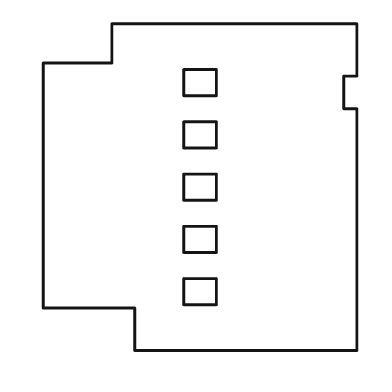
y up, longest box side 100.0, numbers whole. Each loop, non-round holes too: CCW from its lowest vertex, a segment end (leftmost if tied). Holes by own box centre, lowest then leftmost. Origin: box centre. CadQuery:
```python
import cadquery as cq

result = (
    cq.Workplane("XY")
    .moveTo(-20.0, -50.0)
    .lineTo(48.0, -50.0)
    .lineTo(48.0, 24.0)
    .lineTo(44.0, 24.0)
    .lineTo(44.0, 34.0)
    .lineTo(48.0, 34.0)
    .lineTo(48.0, 50.0)
    .lineTo(-27.0, 50.0)
    .lineTo(-27.0, 38.0)
    .lineTo(-48.0, 38.0)
    .lineTo(-48.0, -37.0)
    .lineTo(-20.0, -37.0)
    .close()
    .moveTo(-5.0, -36.0)
    .lineTo(5.0, -36.0)
    .lineTo(5.0, -28.0)
    .lineTo(-5.0, -28.0)
    .close()
    .moveTo(-5.0, -20.0)
    .lineTo(5.0, -20.0)
    .lineTo(5.0, -12.0)
    .lineTo(-5.0, -12.0)
    .close()
    .moveTo(-5.0, -4.0)
    .lineTo(5.0, -4.0)
    .lineTo(5.0, 4.0)
    .lineTo(-5.0, 4.0)
    .close()
    .moveTo(-5.0, 12.0)
    .lineTo(5.0, 12.0)
    .lineTo(5.0, 20.0)
    .lineTo(-5.0, 20.0)
    .close()
    .moveTo(-5.0, 28.0)
    .lineTo(5.0, 28.0)
    .lineTo(5.0, 36.0)
    .lineTo(-5.0, 36.0)
    .close()
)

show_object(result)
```